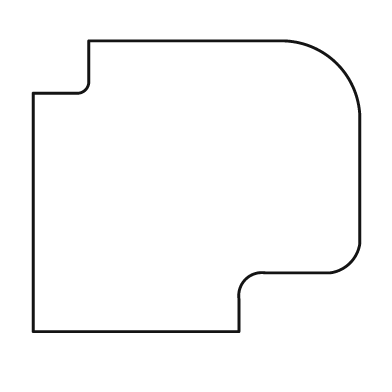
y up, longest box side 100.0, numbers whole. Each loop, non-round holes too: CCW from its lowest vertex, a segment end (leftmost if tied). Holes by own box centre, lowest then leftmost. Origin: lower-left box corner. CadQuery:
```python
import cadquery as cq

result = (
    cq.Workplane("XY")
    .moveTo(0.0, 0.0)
    .lineTo(63.0, 0.0)
    .lineTo(63.0, 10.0)
    .threePointArc((65.0, 16.0), (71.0, 18.0))
    .lineTo(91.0, 18.0)
    .threePointArc((97.0, 21.0), (100.0, 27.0))
    .lineTo(100.0, 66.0)
    .threePointArc((93.0, 82.0), (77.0, 89.0))
    .lineTo(17.0, 89.0)
    .lineTo(17.0, 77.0)
    .threePointArc((16.0, 74.0), (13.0, 73.0))
    .lineTo(0.0, 73.0)
    .close()
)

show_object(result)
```